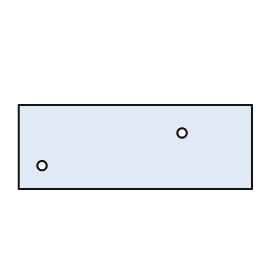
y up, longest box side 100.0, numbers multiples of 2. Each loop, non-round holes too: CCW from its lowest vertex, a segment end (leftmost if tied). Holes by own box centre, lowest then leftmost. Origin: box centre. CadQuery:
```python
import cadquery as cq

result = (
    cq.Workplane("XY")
    .moveTo(-50.0, -18.0)
    .lineTo(50.0, -18.0)
    .lineTo(50.0, 18.0)
    .lineTo(-50.0, 18.0)
    .close()
    .moveTo(-40.0, -8.0)
    .circle(2.0)
    .moveTo(20.0, 6.0)
    .circle(2.0)
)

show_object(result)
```